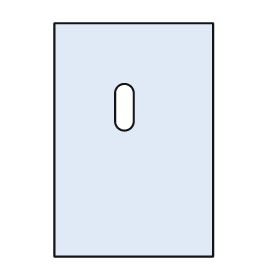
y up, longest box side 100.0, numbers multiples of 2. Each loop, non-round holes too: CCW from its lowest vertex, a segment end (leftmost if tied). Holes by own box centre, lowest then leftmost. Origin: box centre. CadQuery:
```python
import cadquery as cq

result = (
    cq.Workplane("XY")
    .moveTo(-34.0, -50.0)
    .lineTo(34.0, -50.0)
    .lineTo(34.0, 50.0)
    .lineTo(-34.0, 50.0)
    .close()
    .moveTo(-8.0, 8.0)
    .threePointArc((-4.0, 4.0), (0.0, 8.0))
    .lineTo(0.0, 20.0)
    .threePointArc((-4.0, 24.0), (-8.0, 20.0))
    .close()
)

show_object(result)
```